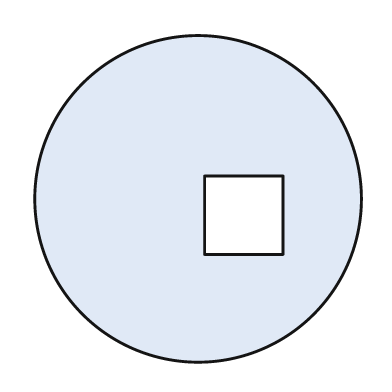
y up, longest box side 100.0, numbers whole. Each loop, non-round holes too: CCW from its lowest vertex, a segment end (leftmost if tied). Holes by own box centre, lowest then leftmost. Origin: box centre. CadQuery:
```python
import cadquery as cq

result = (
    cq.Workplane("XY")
    .moveTo(0.0, 0.0)
    .circle(50.0)
    .moveTo(2.0, -17.0)
    .lineTo(26.0, -17.0)
    .lineTo(26.0, 7.0)
    .lineTo(2.0, 7.0)
    .close()
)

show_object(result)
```